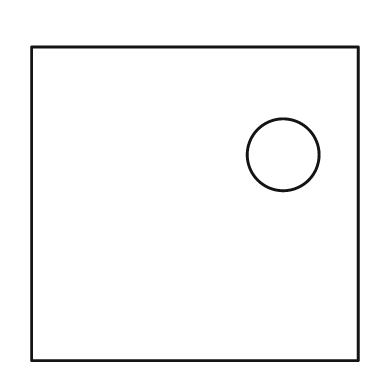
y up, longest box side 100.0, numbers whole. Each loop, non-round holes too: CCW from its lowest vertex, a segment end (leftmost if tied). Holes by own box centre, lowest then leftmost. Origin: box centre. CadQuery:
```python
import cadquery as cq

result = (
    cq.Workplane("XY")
    .moveTo(-50.0, -48.0)
    .lineTo(50.0, -48.0)
    .lineTo(50.0, 48.0)
    .lineTo(-50.0, 48.0)
    .close()
    .moveTo(27.0, 15.0)
    .circle(11.0)
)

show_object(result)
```